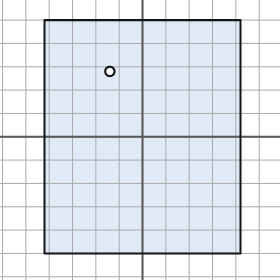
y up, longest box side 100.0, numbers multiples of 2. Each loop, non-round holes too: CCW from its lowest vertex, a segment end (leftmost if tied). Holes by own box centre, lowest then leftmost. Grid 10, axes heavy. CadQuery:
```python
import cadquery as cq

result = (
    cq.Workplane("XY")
    .moveTo(-42.0, -50.0)
    .lineTo(42.0, -50.0)
    .lineTo(42.0, 50.0)
    .lineTo(-42.0, 50.0)
    .close()
    .moveTo(-14.0, 28.0)
    .circle(2.0)
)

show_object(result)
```